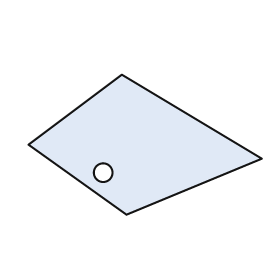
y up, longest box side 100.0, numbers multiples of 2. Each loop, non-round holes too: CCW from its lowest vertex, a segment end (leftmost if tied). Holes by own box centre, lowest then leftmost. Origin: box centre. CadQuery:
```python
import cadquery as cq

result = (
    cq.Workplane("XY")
    .moveTo(-8.0, -30.0)
    .lineTo(50.0, -6.0)
    .lineTo(-10.0, 30.0)
    .lineTo(-50.0, 0.0)
    .close()
    .moveTo(-18.0, -12.0)
    .circle(4.0)
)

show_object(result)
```